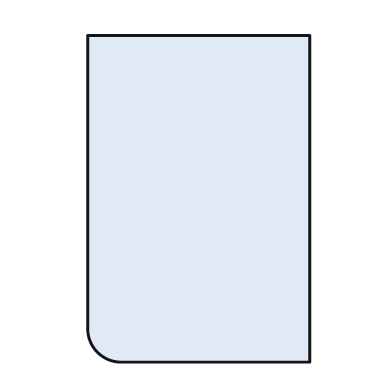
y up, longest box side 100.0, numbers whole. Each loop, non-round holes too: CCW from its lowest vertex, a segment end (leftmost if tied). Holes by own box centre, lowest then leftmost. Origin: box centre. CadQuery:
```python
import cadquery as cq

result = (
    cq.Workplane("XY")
    .moveTo(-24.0, -50.0)
    .lineTo(34.0, -50.0)
    .lineTo(34.0, 50.0)
    .lineTo(-34.0, 50.0)
    .lineTo(-34.0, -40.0)
    .threePointArc((-31.0, -47.0), (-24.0, -50.0))
    .close()
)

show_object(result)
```